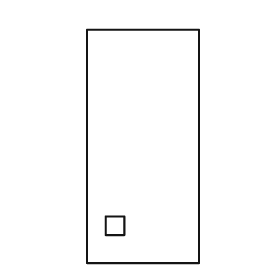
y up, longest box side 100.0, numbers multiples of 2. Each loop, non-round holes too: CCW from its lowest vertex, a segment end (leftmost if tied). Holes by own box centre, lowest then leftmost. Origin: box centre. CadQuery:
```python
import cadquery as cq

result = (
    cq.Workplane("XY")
    .moveTo(-24.0, -50.0)
    .lineTo(24.0, -50.0)
    .lineTo(24.0, 50.0)
    .lineTo(-24.0, 50.0)
    .close()
    .moveTo(-16.0, -38.0)
    .lineTo(-8.0, -38.0)
    .lineTo(-8.0, -30.0)
    .lineTo(-16.0, -30.0)
    .close()
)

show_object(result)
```